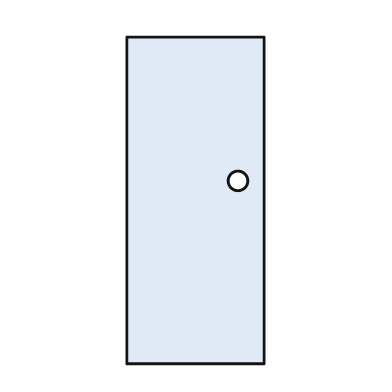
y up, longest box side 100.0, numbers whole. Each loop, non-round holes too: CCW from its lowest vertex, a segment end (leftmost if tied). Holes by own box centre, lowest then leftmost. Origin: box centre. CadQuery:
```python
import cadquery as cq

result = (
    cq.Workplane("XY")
    .moveTo(-21.0, -50.0)
    .lineTo(21.0, -50.0)
    .lineTo(21.0, 50.0)
    .lineTo(-21.0, 50.0)
    .close()
    .moveTo(13.0, 6.0)
    .circle(3.0)
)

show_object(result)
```